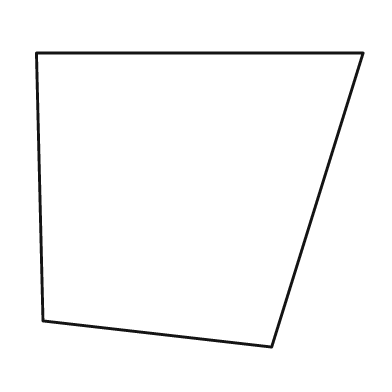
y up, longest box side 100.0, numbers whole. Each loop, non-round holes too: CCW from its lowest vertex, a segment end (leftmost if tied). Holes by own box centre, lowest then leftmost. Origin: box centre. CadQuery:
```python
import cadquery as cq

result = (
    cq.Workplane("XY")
    .moveTo(22.0, -45.0)
    .lineTo(50.0, 45.0)
    .lineTo(-50.0, 45.0)
    .lineTo(-48.0, -37.0)
    .close()
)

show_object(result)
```